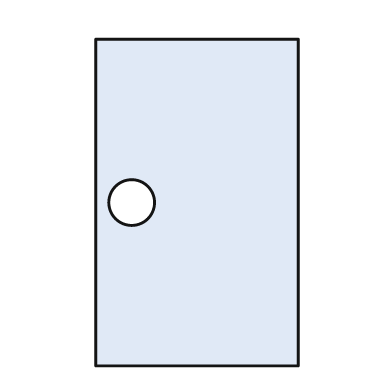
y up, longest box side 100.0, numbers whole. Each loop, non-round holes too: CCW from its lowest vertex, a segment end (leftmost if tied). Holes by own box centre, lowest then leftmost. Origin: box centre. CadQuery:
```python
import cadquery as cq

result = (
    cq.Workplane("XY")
    .moveTo(-31.0, -50.0)
    .lineTo(31.0, -50.0)
    .lineTo(31.0, 50.0)
    .lineTo(-31.0, 50.0)
    .close()
    .moveTo(-20.0, 0.0)
    .circle(7.0)
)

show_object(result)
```